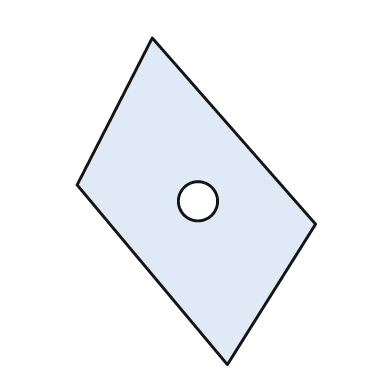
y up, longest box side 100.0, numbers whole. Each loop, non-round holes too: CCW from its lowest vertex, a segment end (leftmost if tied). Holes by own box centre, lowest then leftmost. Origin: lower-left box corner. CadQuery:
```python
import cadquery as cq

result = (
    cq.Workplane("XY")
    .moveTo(46.0, 0.0)
    .lineTo(73.0, 43.0)
    .lineTo(23.0, 100.0)
    .lineTo(0.0, 55.0)
    .close()
    .moveTo(37.0, 50.0)
    .circle(6.0)
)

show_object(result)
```